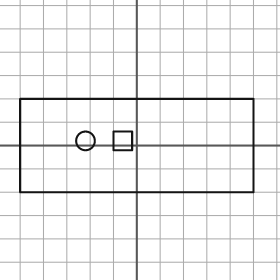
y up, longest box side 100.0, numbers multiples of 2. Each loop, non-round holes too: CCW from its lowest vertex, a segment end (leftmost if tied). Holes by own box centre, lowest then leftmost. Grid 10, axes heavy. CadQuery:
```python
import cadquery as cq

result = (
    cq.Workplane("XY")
    .moveTo(-50.0, -20.0)
    .lineTo(50.0, -20.0)
    .lineTo(50.0, 20.0)
    .lineTo(-50.0, 20.0)
    .close()
    .moveTo(-22.0, 2.0)
    .circle(4.0)
    .moveTo(-10.0, -2.0)
    .lineTo(-2.0, -2.0)
    .lineTo(-2.0, 6.0)
    .lineTo(-10.0, 6.0)
    .close()
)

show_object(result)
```